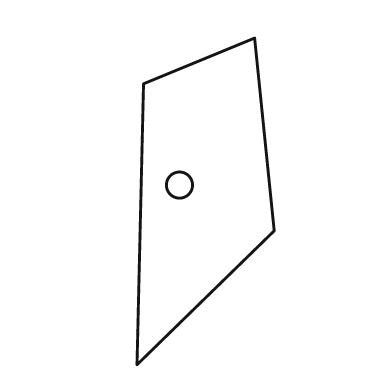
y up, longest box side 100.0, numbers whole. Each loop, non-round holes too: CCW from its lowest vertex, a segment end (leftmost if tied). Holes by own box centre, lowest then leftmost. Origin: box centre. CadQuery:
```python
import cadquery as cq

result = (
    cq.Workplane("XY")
    .moveTo(-21.0, -50.0)
    .lineTo(21.0, -9.0)
    .lineTo(15.0, 50.0)
    .lineTo(-19.0, 36.0)
    .close()
    .moveTo(-8.0, 5.0)
    .circle(4.0)
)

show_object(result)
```